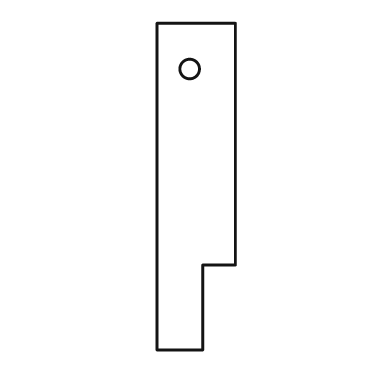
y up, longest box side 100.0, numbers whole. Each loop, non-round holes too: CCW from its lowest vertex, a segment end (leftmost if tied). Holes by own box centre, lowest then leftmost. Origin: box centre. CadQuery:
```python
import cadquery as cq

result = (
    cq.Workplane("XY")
    .moveTo(-12.0, -50.0)
    .lineTo(2.0, -50.0)
    .lineTo(2.0, -24.0)
    .lineTo(12.0, -24.0)
    .lineTo(12.0, 50.0)
    .lineTo(-12.0, 50.0)
    .close()
    .moveTo(-2.0, 36.0)
    .circle(3.0)
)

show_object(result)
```